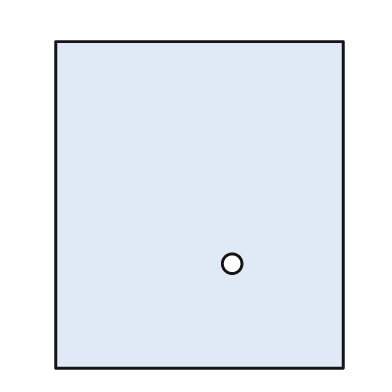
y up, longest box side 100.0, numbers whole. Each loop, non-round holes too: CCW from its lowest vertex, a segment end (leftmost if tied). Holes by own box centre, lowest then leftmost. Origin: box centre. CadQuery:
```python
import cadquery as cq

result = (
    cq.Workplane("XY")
    .moveTo(-44.0, -50.0)
    .lineTo(44.0, -50.0)
    .lineTo(44.0, 50.0)
    .lineTo(-44.0, 50.0)
    .close()
    .moveTo(10.0, -18.0)
    .circle(3.0)
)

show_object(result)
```